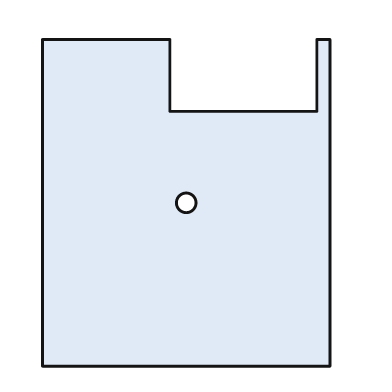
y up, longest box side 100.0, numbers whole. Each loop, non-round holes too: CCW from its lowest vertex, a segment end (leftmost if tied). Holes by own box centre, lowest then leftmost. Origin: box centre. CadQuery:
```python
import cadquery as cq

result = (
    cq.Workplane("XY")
    .moveTo(-44.0, -50.0)
    .lineTo(44.0, -50.0)
    .lineTo(44.0, 50.0)
    .lineTo(40.0, 50.0)
    .lineTo(40.0, 28.0)
    .lineTo(-5.0, 28.0)
    .lineTo(-5.0, 50.0)
    .lineTo(-44.0, 50.0)
    .close()
    .moveTo(0.0, 0.0)
    .circle(3.0)
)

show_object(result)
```